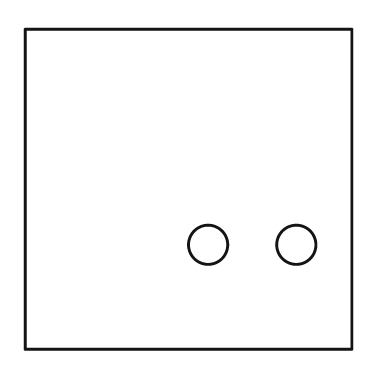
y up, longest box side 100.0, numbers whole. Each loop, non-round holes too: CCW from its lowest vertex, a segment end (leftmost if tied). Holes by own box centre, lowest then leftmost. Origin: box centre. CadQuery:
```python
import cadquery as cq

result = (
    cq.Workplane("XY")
    .moveTo(-50.0, -49.0)
    .lineTo(50.0, -49.0)
    .lineTo(50.0, 49.0)
    .lineTo(-50.0, 49.0)
    .close()
    .moveTo(6.0, -17.0)
    .circle(6.0)
    .moveTo(33.0, -17.0)
    .circle(6.0)
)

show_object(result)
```